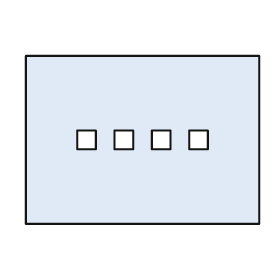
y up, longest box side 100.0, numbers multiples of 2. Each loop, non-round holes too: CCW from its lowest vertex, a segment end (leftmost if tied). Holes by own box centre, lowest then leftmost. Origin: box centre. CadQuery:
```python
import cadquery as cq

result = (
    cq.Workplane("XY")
    .moveTo(-50.0, -36.0)
    .lineTo(50.0, -36.0)
    .lineTo(50.0, 36.0)
    .lineTo(-50.0, 36.0)
    .close()
    .moveTo(-28.0, -4.0)
    .lineTo(-20.0, -4.0)
    .lineTo(-20.0, 4.0)
    .lineTo(-28.0, 4.0)
    .close()
    .moveTo(-12.0, -4.0)
    .lineTo(-4.0, -4.0)
    .lineTo(-4.0, 4.0)
    .lineTo(-12.0, 4.0)
    .close()
    .moveTo(4.0, -4.0)
    .lineTo(12.0, -4.0)
    .lineTo(12.0, 4.0)
    .lineTo(4.0, 4.0)
    .close()
    .moveTo(20.0, -4.0)
    .lineTo(28.0, -4.0)
    .lineTo(28.0, 4.0)
    .lineTo(20.0, 4.0)
    .close()
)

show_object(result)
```